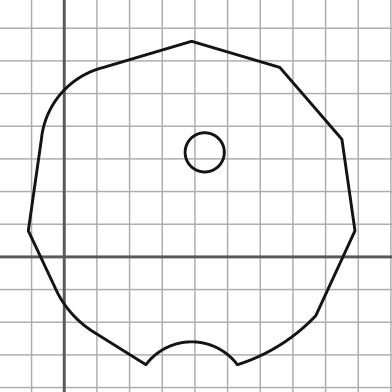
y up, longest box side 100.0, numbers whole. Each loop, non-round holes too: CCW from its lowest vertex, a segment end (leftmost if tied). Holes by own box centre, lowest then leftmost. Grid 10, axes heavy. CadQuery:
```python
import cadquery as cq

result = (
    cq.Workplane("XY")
    .moveTo(25.0, -33.0)
    .threePointArc((39.0, -26.0), (53.0, -33.0))
    .threePointArc((66.0, -27.0), (77.0, -18.0))
    .lineTo(89.0, 8.0)
    .lineTo(85.0, 36.0)
    .lineTo(66.0, 58.0)
    .lineTo(39.0, 66.0)
    .lineTo(12.0, 58.0)
    .threePointArc((-1.0, 50.0), (-7.0, 36.0))
    .lineTo(-11.0, 8.0)
    .lineTo(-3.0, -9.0)
    .threePointArc((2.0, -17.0), (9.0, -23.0))
    .close()
    .moveTo(43.0, 32.0)
    .circle(6.0)
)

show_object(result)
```